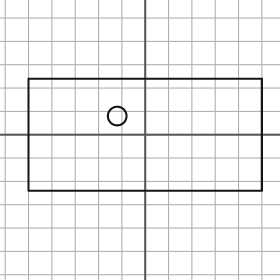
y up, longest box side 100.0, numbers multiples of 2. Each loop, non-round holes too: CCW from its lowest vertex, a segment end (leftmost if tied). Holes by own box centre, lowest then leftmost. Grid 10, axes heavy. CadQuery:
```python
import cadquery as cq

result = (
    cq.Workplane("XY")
    .moveTo(-50.0, -24.0)
    .lineTo(50.0, -24.0)
    .lineTo(50.0, 24.0)
    .lineTo(-50.0, 24.0)
    .close()
    .moveTo(-12.0, 8.0)
    .circle(4.0)
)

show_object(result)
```